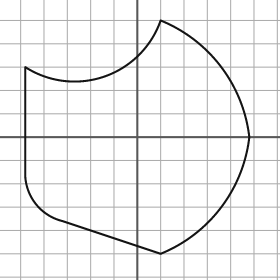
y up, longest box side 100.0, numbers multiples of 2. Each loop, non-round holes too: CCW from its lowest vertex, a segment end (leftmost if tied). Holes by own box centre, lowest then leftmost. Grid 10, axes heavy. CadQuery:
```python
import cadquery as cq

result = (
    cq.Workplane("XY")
    .moveTo(10.0, -50.0)
    .threePointArc((36.0, -30.0), (48.0, 0.0))
    .threePointArc((36.0, 30.0), (10.0, 50.0))
    .threePointArc((-14.0, 26.0), (-48.0, 30.0))
    .lineTo(-48.0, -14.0)
    .threePointArc((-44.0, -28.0), (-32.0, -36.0))
    .close()
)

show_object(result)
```